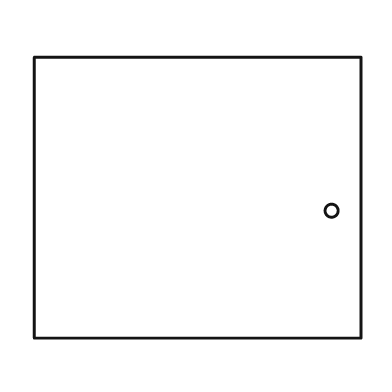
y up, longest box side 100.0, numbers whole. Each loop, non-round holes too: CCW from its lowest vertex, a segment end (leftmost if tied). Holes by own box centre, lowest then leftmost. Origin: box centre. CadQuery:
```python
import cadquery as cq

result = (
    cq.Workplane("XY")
    .moveTo(-50.0, -43.0)
    .lineTo(50.0, -43.0)
    .lineTo(50.0, 43.0)
    .lineTo(-50.0, 43.0)
    .close()
    .moveTo(41.0, -4.0)
    .circle(2.0)
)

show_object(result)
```